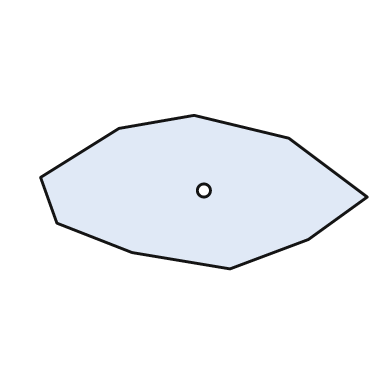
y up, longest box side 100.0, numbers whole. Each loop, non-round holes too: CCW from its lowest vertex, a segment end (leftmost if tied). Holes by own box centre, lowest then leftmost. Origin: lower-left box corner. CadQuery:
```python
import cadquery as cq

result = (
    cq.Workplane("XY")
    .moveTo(58.0, 0.0)
    .lineTo(82.0, 9.0)
    .lineTo(100.0, 22.0)
    .lineTo(76.0, 40.0)
    .lineTo(47.0, 47.0)
    .lineTo(24.0, 43.0)
    .lineTo(0.0, 28.0)
    .lineTo(5.0, 14.0)
    .lineTo(28.0, 5.0)
    .close()
    .moveTo(50.0, 24.0)
    .circle(2.0)
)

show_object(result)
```